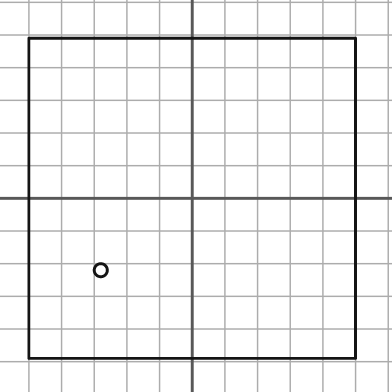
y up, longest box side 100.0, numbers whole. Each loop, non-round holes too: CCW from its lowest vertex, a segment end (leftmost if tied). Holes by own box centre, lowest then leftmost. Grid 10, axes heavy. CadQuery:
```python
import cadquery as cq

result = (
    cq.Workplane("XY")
    .moveTo(-50.0, -49.0)
    .lineTo(50.0, -49.0)
    .lineTo(50.0, 49.0)
    .lineTo(-50.0, 49.0)
    .close()
    .moveTo(-28.0, -22.0)
    .circle(2.0)
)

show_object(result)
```